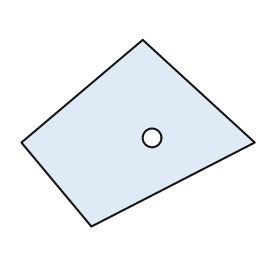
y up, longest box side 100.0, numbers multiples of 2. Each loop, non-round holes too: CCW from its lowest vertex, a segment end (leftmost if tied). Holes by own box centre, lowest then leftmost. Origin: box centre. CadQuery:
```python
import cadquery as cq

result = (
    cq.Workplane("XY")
    .moveTo(-20.0, -40.0)
    .lineTo(50.0, -4.0)
    .lineTo(2.0, 40.0)
    .lineTo(-50.0, -4.0)
    .close()
    .moveTo(6.0, -2.0)
    .circle(4.0)
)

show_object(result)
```